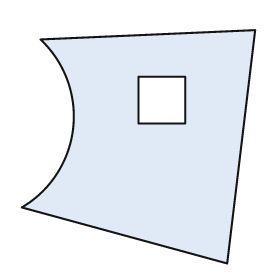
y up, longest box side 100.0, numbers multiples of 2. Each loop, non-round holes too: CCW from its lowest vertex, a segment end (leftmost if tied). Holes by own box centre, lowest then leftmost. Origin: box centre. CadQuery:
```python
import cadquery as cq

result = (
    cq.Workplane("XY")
    .moveTo(38.0, -50.0)
    .lineTo(50.0, 50.0)
    .lineTo(-42.0, 46.0)
    .threePointArc((-28.0, 8.0), (-50.0, -26.0))
    .close()
    .moveTo(0.0, 10.0)
    .lineTo(20.0, 10.0)
    .lineTo(20.0, 30.0)
    .lineTo(0.0, 30.0)
    .close()
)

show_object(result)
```